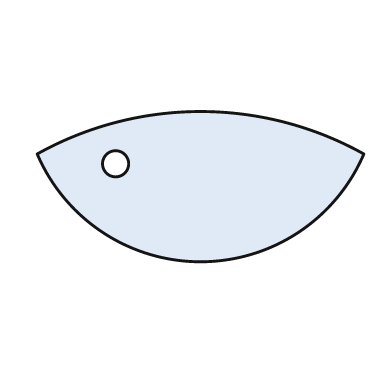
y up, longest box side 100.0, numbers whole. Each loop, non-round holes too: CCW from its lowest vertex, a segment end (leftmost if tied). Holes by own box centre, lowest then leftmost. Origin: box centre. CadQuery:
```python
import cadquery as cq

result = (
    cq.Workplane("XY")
    .moveTo(-50.0, 10.0)
    .threePointArc((0.0, -23.0), (50.0, 10.0))
    .threePointArc((0.0, 23.0), (-50.0, 10.0))
    .close()
    .moveTo(-26.0, 7.0)
    .circle(4.0)
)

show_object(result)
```